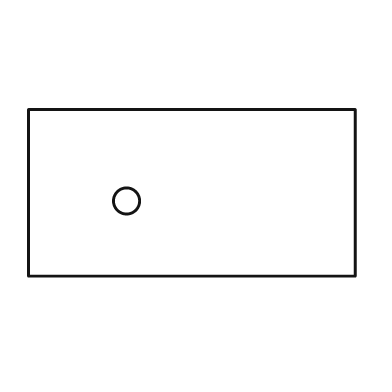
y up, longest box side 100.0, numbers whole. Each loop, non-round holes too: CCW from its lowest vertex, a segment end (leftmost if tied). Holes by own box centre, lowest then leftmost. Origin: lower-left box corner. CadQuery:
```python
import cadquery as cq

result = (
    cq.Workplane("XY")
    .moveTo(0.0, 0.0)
    .lineTo(100.0, 0.0)
    .lineTo(100.0, 51.0)
    .lineTo(0.0, 51.0)
    .close()
    .moveTo(30.0, 23.0)
    .circle(4.0)
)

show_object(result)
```